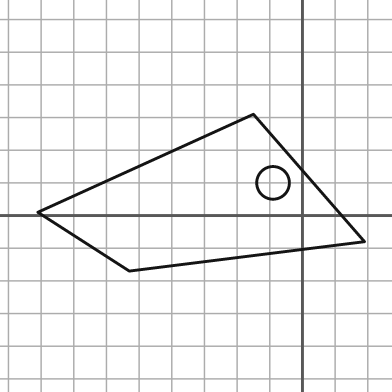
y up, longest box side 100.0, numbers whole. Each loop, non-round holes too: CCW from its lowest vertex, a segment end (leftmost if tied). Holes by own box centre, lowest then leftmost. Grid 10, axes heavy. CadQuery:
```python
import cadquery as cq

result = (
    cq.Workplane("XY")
    .moveTo(-53.0, -17.0)
    .lineTo(19.0, -8.0)
    .lineTo(-15.0, 31.0)
    .lineTo(-81.0, 1.0)
    .close()
    .moveTo(-9.0, 10.0)
    .circle(5.0)
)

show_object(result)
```